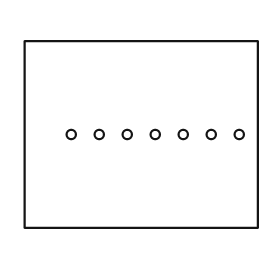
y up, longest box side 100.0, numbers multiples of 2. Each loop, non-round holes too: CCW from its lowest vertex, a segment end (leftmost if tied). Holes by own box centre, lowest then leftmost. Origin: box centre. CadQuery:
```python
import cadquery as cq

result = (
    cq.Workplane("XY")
    .moveTo(-50.0, -40.0)
    .lineTo(50.0, -40.0)
    .lineTo(50.0, 40.0)
    .lineTo(-50.0, 40.0)
    .close()
    .moveTo(-30.0, 0.0)
    .circle(2.0)
    .moveTo(-18.0, 0.0)
    .circle(2.0)
    .moveTo(-6.0, 0.0)
    .circle(2.0)
    .moveTo(6.0, 0.0)
    .circle(2.0)
    .moveTo(18.0, 0.0)
    .circle(2.0)
    .moveTo(30.0, 0.0)
    .circle(2.0)
    .moveTo(42.0, 0.0)
    .circle(2.0)
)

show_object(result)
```